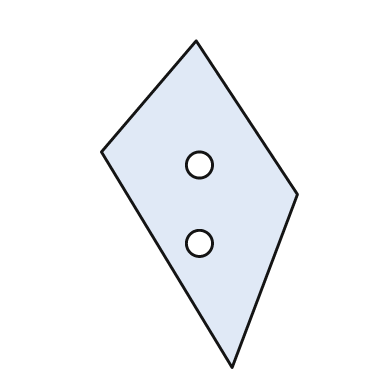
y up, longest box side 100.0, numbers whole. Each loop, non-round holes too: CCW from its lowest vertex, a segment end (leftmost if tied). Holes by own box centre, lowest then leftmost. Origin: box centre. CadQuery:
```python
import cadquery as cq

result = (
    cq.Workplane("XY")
    .moveTo(10.0, -50.0)
    .lineTo(30.0, 3.0)
    .lineTo(-1.0, 50.0)
    .lineTo(-30.0, 16.0)
    .close()
    .moveTo(0.0, -12.0)
    .circle(4.0)
    .moveTo(0.0, 12.0)
    .circle(4.0)
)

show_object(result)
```